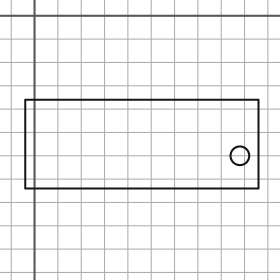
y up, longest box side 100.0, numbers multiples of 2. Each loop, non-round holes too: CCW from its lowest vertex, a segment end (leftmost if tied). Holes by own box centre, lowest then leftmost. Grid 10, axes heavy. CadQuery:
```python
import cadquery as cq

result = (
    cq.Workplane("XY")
    .moveTo(-4.0, -74.0)
    .lineTo(96.0, -74.0)
    .lineTo(96.0, -36.0)
    .lineTo(-4.0, -36.0)
    .close()
    .moveTo(88.0, -60.0)
    .circle(4.0)
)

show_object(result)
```